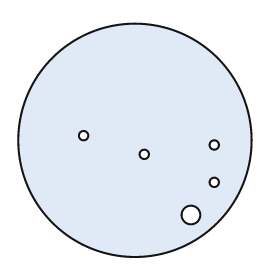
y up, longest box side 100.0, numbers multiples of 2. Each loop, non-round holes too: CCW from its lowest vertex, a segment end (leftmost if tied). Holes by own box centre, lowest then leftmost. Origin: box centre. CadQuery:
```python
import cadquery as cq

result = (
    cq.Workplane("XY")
    .moveTo(0.0, 0.0)
    .circle(50.0)
    .moveTo(24.0, -32.0)
    .circle(4.0)
    .moveTo(34.0, -18.0)
    .circle(2.0)
    .moveTo(4.0, -6.0)
    .circle(2.0)
    .moveTo(34.0, -2.0)
    .circle(2.0)
    .moveTo(-22.0, 2.0)
    .circle(2.0)
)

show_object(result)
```